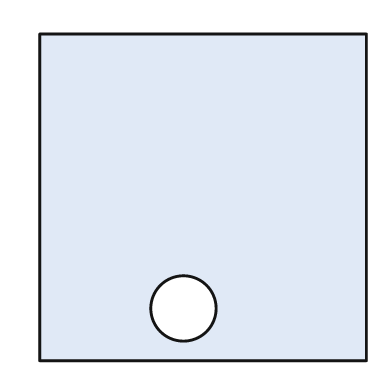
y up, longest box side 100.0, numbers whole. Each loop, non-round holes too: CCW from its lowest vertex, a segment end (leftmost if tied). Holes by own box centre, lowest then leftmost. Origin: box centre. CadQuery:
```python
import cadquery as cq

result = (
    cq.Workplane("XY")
    .moveTo(-50.0, -50.0)
    .lineTo(50.0, -50.0)
    .lineTo(50.0, 50.0)
    .lineTo(-50.0, 50.0)
    .close()
    .moveTo(-6.0, -34.0)
    .circle(10.0)
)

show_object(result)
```